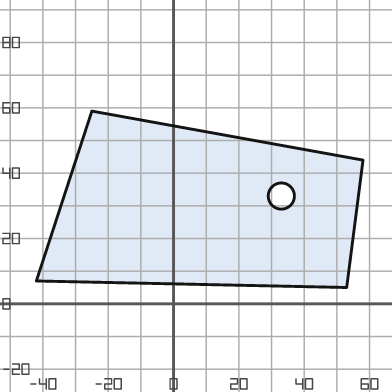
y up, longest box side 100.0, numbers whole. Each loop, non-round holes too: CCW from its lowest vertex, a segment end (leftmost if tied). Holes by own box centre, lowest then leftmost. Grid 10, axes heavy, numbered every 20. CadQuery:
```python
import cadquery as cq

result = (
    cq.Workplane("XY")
    .moveTo(53.0, 5.0)
    .lineTo(58.0, 44.0)
    .lineTo(-25.0, 59.0)
    .lineTo(-42.0, 7.0)
    .close()
    .moveTo(33.0, 33.0)
    .circle(4.0)
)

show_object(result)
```